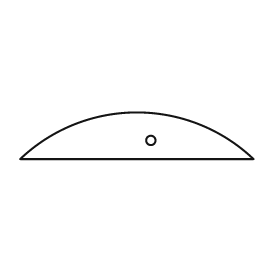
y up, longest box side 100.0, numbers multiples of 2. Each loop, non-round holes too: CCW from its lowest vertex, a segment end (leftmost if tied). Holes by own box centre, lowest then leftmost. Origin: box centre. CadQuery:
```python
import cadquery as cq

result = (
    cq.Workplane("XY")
    .moveTo(-50.0, -10.0)
    .lineTo(50.0, -10.0)
    .threePointArc((0.0, 10.0), (-50.0, -10.0))
    .close()
    .moveTo(6.0, -2.0)
    .circle(2.0)
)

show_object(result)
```